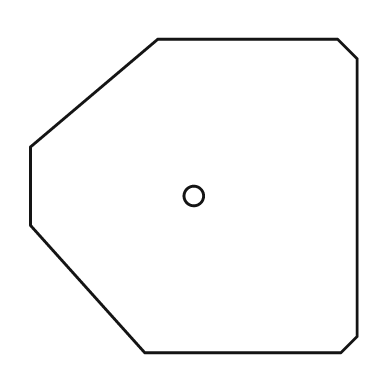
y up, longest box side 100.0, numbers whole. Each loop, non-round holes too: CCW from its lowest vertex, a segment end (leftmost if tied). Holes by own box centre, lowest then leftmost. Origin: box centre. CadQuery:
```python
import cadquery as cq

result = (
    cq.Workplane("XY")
    .moveTo(-15.0, -48.0)
    .lineTo(45.0, -48.0)
    .lineTo(50.0, -43.0)
    .lineTo(50.0, 42.0)
    .lineTo(44.0, 48.0)
    .lineTo(-11.0, 48.0)
    .lineTo(-50.0, 15.0)
    .lineTo(-50.0, -9.0)
    .close()
    .moveTo(0.0, 0.0)
    .circle(3.0)
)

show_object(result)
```